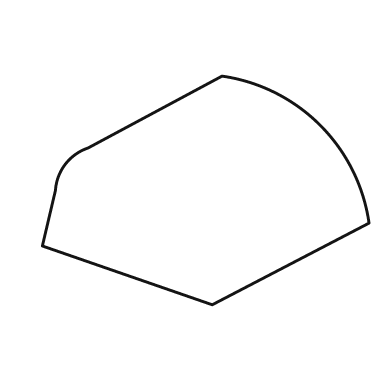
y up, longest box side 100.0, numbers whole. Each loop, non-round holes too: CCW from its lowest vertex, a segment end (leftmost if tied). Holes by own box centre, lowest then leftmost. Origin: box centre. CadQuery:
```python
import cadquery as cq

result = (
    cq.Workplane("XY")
    .moveTo(2.0, -35.0)
    .lineTo(50.0, -10.0)
    .threePointArc((35.0, 20.0), (5.0, 35.0))
    .lineTo(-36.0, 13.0)
    .threePointArc((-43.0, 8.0), (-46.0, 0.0))
    .lineTo(-50.0, -17.0)
    .close()
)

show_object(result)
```